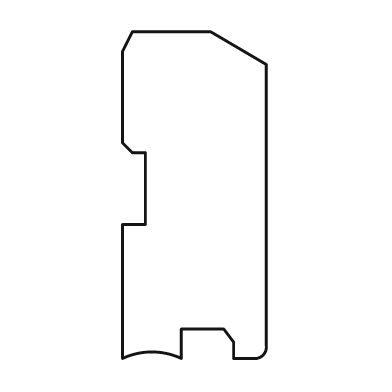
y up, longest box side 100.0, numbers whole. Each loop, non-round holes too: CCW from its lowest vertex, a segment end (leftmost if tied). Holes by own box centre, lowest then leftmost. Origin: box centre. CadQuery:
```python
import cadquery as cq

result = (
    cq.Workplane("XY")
    .moveTo(-22.0, -50.0)
    .threePointArc((-13.0, -48.0), (-4.0, -50.0))
    .lineTo(-4.0, -41.0)
    .lineTo(9.0, -41.0)
    .lineTo(12.0, -45.0)
    .lineTo(12.0, -50.0)
    .lineTo(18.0, -50.0)
    .threePointArc((21.0, -49.0), (22.0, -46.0))
    .lineTo(22.0, 40.0)
    .lineTo(5.0, 50.0)
    .lineTo(-19.0, 50.0)
    .lineTo(-22.0, 44.0)
    .lineTo(-22.0, 16.0)
    .lineTo(-19.0, 13.0)
    .lineTo(-15.0, 13.0)
    .lineTo(-15.0, -9.0)
    .lineTo(-22.0, -9.0)
    .close()
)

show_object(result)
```